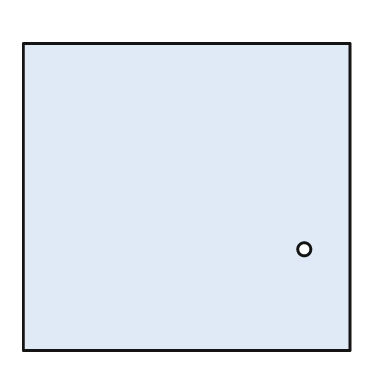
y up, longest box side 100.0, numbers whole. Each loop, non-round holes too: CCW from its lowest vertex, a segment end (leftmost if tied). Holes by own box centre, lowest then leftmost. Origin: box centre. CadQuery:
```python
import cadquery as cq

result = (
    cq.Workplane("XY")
    .moveTo(-50.0, -47.0)
    .lineTo(50.0, -47.0)
    .lineTo(50.0, 47.0)
    .lineTo(-50.0, 47.0)
    .close()
    .moveTo(36.0, -16.0)
    .circle(2.0)
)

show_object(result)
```